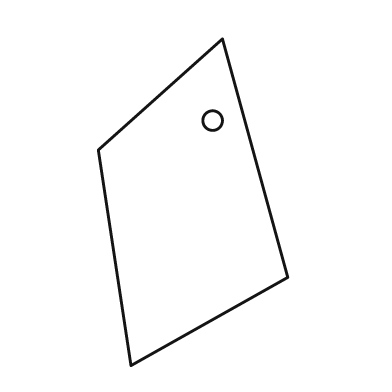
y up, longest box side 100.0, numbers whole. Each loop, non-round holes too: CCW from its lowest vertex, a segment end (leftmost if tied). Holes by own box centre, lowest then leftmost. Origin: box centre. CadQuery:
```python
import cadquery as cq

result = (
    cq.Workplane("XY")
    .moveTo(-19.0, -50.0)
    .lineTo(29.0, -23.0)
    .lineTo(9.0, 50.0)
    .lineTo(-29.0, 16.0)
    .close()
    .moveTo(6.0, 25.0)
    .circle(3.0)
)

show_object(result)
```